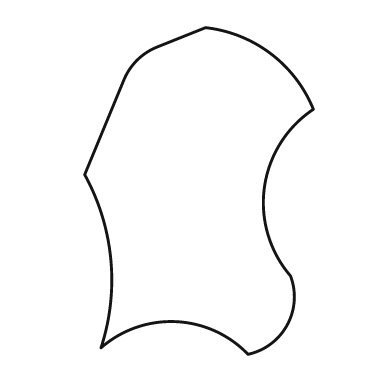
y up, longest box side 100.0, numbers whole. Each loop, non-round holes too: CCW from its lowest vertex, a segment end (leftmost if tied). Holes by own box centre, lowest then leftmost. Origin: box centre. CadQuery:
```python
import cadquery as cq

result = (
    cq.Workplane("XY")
    .moveTo(15.0, -50.0)
    .threePointArc((27.0, -41.0), (28.0, -26.0))
    .threePointArc((20.0, 1.0), (35.0, 25.0))
    .threePointArc((22.0, 42.0), (2.0, 50.0))
    .lineTo(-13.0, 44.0)
    .threePointArc((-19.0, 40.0), (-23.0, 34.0))
    .lineTo(-35.0, 5.0)
    .threePointArc((-27.0, -21.0), (-30.0, -48.0))
    .threePointArc((-7.0, -40.0), (15.0, -50.0))
    .close()
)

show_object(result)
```